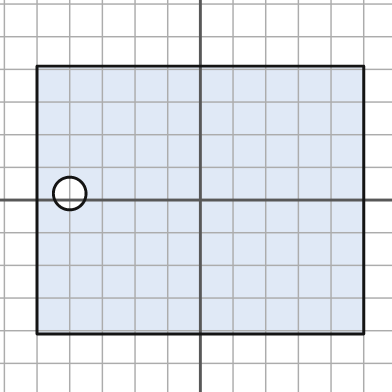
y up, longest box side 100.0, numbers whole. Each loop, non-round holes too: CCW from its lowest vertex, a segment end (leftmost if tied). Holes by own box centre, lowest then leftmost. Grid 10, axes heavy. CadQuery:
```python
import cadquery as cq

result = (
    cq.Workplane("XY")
    .moveTo(-50.0, -41.0)
    .lineTo(50.0, -41.0)
    .lineTo(50.0, 41.0)
    .lineTo(-50.0, 41.0)
    .close()
    .moveTo(-40.0, 2.0)
    .circle(5.0)
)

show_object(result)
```